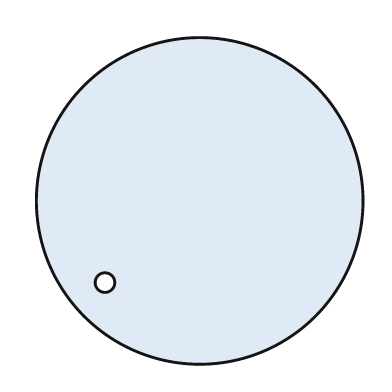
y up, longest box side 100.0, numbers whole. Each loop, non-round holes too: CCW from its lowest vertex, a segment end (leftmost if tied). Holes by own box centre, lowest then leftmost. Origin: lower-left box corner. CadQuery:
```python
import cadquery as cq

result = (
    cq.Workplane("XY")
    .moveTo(50.0, 50.0)
    .circle(50.0)
    .moveTo(21.0, 25.0)
    .circle(3.0)
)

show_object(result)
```